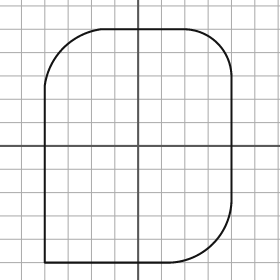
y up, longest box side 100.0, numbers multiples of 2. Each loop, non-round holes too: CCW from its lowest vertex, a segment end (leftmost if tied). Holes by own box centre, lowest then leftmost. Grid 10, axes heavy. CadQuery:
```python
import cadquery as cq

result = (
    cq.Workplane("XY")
    .moveTo(-40.0, -50.0)
    .lineTo(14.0, -50.0)
    .threePointArc((32.0, -42.0), (40.0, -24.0))
    .lineTo(40.0, 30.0)
    .threePointArc((34.0, 44.0), (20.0, 50.0))
    .lineTo(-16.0, 50.0)
    .threePointArc((-32.0, 42.0), (-40.0, 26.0))
    .close()
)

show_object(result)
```